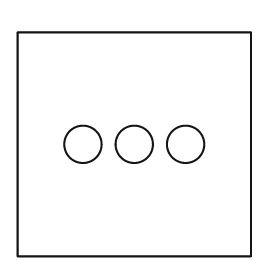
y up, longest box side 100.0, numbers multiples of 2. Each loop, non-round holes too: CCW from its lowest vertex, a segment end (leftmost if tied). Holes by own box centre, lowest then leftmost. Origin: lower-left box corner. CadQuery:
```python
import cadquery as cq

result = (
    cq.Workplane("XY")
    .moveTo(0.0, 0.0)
    .lineTo(100.0, 0.0)
    .lineTo(100.0, 96.0)
    .lineTo(0.0, 96.0)
    .close()
    .moveTo(28.0, 48.0)
    .circle(8.0)
    .moveTo(50.0, 48.0)
    .circle(8.0)
    .moveTo(72.0, 48.0)
    .circle(8.0)
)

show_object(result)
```